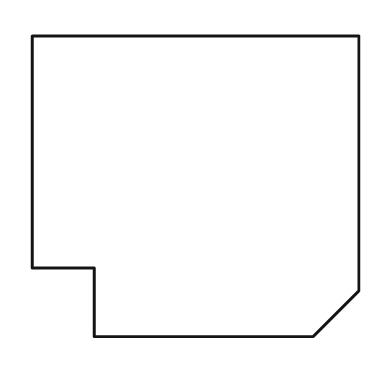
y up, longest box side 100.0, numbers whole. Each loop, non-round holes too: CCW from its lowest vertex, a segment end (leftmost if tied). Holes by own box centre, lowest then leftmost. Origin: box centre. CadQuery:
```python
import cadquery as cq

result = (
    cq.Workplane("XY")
    .moveTo(-31.0, -46.0)
    .lineTo(36.0, -46.0)
    .lineTo(50.0, -32.0)
    .lineTo(50.0, 46.0)
    .lineTo(-50.0, 46.0)
    .lineTo(-50.0, -25.0)
    .lineTo(-31.0, -25.0)
    .close()
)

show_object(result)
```